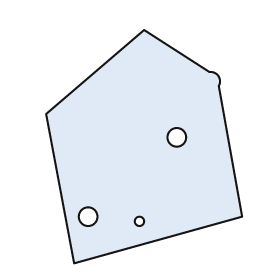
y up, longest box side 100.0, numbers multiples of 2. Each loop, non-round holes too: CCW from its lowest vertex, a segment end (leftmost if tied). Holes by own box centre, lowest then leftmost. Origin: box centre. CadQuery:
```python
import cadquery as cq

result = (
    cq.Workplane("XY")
    .moveTo(-30.0, -50.0)
    .lineTo(42.0, -30.0)
    .lineTo(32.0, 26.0)
    .threePointArc((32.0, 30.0), (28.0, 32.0))
    .lineTo(0.0, 50.0)
    .lineTo(-42.0, 14.0)
    .close()
    .moveTo(-2.0, -32.0)
    .circle(2.0)
    .moveTo(-24.0, -30.0)
    .circle(4.0)
    .moveTo(14.0, 4.0)
    .circle(4.0)
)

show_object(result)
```